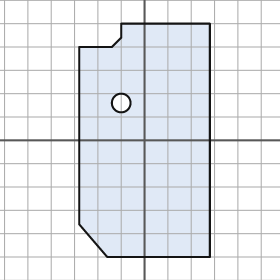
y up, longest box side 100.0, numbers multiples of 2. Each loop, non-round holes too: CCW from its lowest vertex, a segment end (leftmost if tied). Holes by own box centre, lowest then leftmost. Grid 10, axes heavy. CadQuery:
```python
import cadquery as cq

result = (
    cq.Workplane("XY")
    .moveTo(-16.0, -50.0)
    .lineTo(28.0, -50.0)
    .lineTo(28.0, 50.0)
    .lineTo(-10.0, 50.0)
    .lineTo(-10.0, 44.0)
    .lineTo(-14.0, 40.0)
    .lineTo(-28.0, 40.0)
    .lineTo(-28.0, -36.0)
    .close()
    .moveTo(-10.0, 16.0)
    .circle(4.0)
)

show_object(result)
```